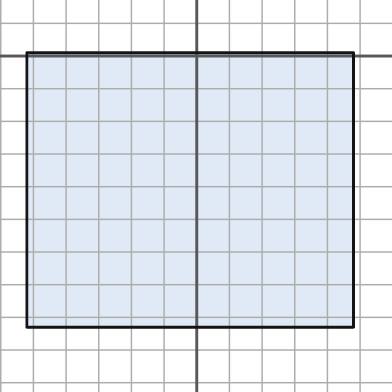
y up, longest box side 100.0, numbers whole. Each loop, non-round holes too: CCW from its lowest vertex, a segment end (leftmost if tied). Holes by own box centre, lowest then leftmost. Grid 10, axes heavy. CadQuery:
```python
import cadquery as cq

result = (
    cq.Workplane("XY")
    .moveTo(-52.0, -83.0)
    .lineTo(48.0, -83.0)
    .lineTo(48.0, 1.0)
    .lineTo(-52.0, 1.0)
    .close()
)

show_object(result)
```